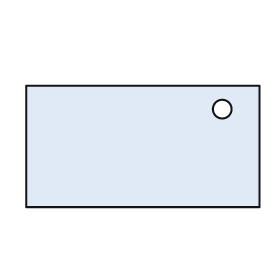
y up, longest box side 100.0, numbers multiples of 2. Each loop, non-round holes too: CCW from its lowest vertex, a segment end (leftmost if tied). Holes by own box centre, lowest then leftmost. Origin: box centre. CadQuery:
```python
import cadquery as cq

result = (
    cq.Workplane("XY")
    .moveTo(-50.0, -26.0)
    .lineTo(50.0, -26.0)
    .lineTo(50.0, 26.0)
    .lineTo(-50.0, 26.0)
    .close()
    .moveTo(34.0, 16.0)
    .circle(4.0)
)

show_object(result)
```